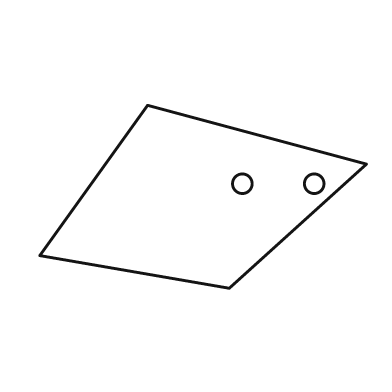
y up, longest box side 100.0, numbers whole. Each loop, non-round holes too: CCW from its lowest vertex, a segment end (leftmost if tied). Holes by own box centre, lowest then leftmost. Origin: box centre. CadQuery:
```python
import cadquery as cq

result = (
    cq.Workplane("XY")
    .moveTo(8.0, -28.0)
    .lineTo(50.0, 10.0)
    .lineTo(-17.0, 28.0)
    .lineTo(-50.0, -18.0)
    .close()
    .moveTo(12.0, 4.0)
    .circle(3.0)
    .moveTo(34.0, 4.0)
    .circle(3.0)
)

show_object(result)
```